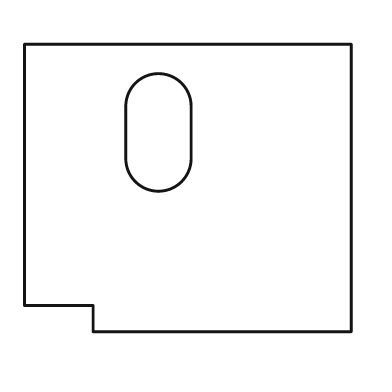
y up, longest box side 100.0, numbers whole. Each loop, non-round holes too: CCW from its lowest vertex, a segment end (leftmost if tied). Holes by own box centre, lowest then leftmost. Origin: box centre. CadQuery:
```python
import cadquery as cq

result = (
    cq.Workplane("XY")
    .moveTo(-29.0, -44.0)
    .lineTo(50.0, -44.0)
    .lineTo(50.0, 44.0)
    .lineTo(-50.0, 44.0)
    .lineTo(-50.0, -36.0)
    .lineTo(-29.0, -36.0)
    .close()
    .moveTo(-19.0, 9.0)
    .threePointArc((-9.0, -1.0), (1.0, 9.0))
    .lineTo(1.0, 25.0)
    .threePointArc((-9.0, 35.0), (-19.0, 25.0))
    .close()
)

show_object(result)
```